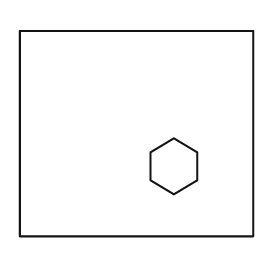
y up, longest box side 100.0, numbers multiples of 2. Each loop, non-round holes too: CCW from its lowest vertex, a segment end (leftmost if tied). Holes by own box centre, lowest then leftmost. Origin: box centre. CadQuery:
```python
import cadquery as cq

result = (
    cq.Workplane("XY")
    .moveTo(-50.0, -44.0)
    .lineTo(50.0, -44.0)
    .lineTo(50.0, 44.0)
    .lineTo(-50.0, 44.0)
    .close()
    .moveTo(16.0, -26.0)
    .lineTo(26.0, -20.0)
    .lineTo(26.0, -8.0)
    .lineTo(16.0, -2.0)
    .lineTo(6.0, -8.0)
    .lineTo(6.0, -20.0)
    .close()
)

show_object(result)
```